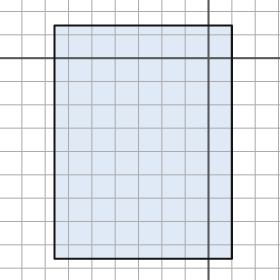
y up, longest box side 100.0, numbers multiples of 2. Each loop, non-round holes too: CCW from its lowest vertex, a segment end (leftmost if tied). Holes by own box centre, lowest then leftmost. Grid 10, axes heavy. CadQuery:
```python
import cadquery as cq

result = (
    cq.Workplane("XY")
    .moveTo(-66.0, -86.0)
    .lineTo(10.0, -86.0)
    .lineTo(10.0, 14.0)
    .lineTo(-66.0, 14.0)
    .close()
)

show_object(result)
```